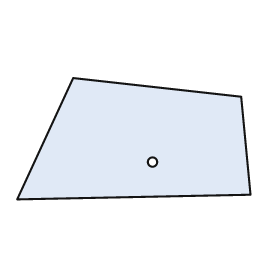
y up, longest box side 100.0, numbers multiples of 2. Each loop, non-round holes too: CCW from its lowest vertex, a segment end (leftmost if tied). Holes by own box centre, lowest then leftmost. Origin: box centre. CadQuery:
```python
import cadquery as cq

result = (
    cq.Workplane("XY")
    .moveTo(-50.0, -26.0)
    .lineTo(50.0, -24.0)
    .lineTo(46.0, 18.0)
    .lineTo(-26.0, 26.0)
    .close()
    .moveTo(8.0, -10.0)
    .circle(2.0)
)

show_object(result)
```